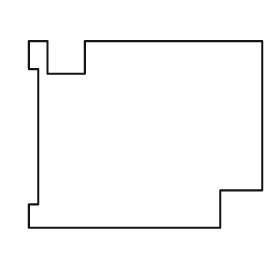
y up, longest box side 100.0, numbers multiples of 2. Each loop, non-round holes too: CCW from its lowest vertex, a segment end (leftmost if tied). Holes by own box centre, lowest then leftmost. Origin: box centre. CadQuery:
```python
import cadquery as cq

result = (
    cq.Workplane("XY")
    .moveTo(-50.0, -40.0)
    .lineTo(32.0, -40.0)
    .lineTo(32.0, -24.0)
    .lineTo(50.0, -24.0)
    .lineTo(50.0, 40.0)
    .lineTo(-26.0, 40.0)
    .lineTo(-26.0, 26.0)
    .lineTo(-42.0, 26.0)
    .lineTo(-42.0, 40.0)
    .lineTo(-50.0, 40.0)
    .lineTo(-50.0, 28.0)
    .lineTo(-46.0, 28.0)
    .lineTo(-46.0, -30.0)
    .lineTo(-50.0, -30.0)
    .close()
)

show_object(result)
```